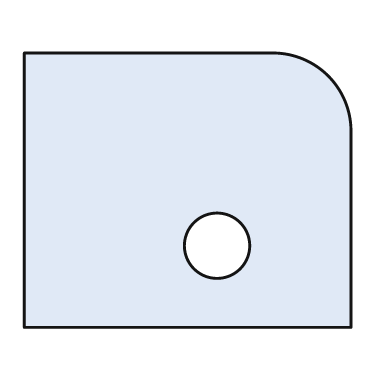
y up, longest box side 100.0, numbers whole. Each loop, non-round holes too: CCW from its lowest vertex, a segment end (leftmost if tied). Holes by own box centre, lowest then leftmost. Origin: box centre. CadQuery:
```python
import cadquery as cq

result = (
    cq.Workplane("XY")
    .moveTo(-50.0, -42.0)
    .lineTo(50.0, -42.0)
    .lineTo(50.0, 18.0)
    .threePointArc((43.0, 35.0), (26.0, 42.0))
    .lineTo(-50.0, 42.0)
    .close()
    .moveTo(9.0, -17.0)
    .circle(10.0)
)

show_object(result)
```